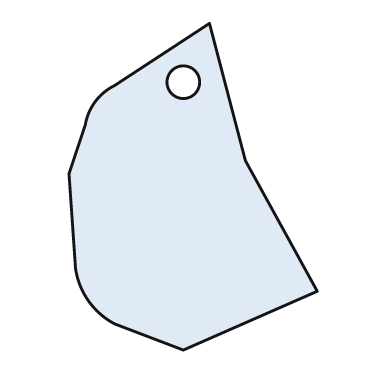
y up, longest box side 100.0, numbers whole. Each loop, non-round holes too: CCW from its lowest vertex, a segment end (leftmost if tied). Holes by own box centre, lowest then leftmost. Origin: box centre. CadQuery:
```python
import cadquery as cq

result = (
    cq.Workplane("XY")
    .moveTo(-3.0, -50.0)
    .lineTo(38.0, -32.0)
    .lineTo(16.0, 8.0)
    .lineTo(5.0, 50.0)
    .lineTo(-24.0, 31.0)
    .threePointArc((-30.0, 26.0), (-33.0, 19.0))
    .lineTo(-38.0, 4.0)
    .lineTo(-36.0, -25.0)
    .threePointArc((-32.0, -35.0), (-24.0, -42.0))
    .close()
    .moveTo(-3.0, 32.0)
    .circle(5.0)
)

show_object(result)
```